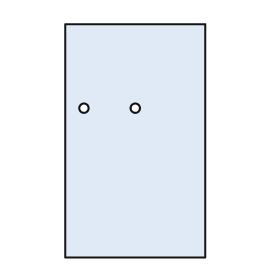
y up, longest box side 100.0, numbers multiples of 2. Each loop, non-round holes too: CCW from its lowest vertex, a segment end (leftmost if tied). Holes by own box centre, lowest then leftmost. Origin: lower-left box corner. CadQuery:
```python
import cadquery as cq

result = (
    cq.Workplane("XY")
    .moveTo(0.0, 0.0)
    .lineTo(60.0, 0.0)
    .lineTo(60.0, 100.0)
    .lineTo(0.0, 100.0)
    .close()
    .moveTo(8.0, 64.0)
    .circle(2.0)
    .moveTo(30.0, 64.0)
    .circle(2.0)
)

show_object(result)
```